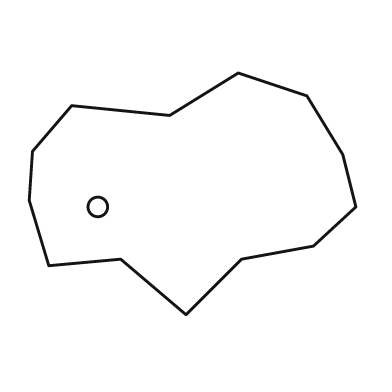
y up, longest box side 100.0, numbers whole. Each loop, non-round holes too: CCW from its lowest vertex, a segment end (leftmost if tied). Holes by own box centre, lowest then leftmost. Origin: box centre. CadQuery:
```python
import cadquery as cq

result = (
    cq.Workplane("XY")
    .moveTo(-2.0, -37.0)
    .lineTo(15.0, -20.0)
    .lineTo(37.0, -16.0)
    .lineTo(50.0, -4.0)
    .lineTo(46.0, 12.0)
    .lineTo(35.0, 30.0)
    .lineTo(14.0, 37.0)
    .lineTo(-7.0, 24.0)
    .lineTo(-37.0, 27.0)
    .lineTo(-49.0, 13.0)
    .lineTo(-50.0, -2.0)
    .lineTo(-44.0, -22.0)
    .lineTo(-22.0, -20.0)
    .close()
    .moveTo(-29.0, -4.0)
    .circle(3.0)
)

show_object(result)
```